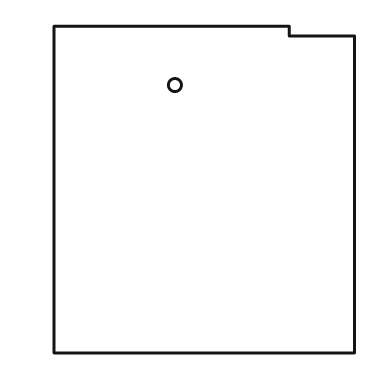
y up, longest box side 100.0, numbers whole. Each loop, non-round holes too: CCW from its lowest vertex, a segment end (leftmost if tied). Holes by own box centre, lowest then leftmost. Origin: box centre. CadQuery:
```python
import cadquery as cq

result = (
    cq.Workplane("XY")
    .moveTo(-46.0, -50.0)
    .lineTo(46.0, -50.0)
    .lineTo(46.0, 47.0)
    .lineTo(26.0, 47.0)
    .lineTo(26.0, 50.0)
    .lineTo(-46.0, 50.0)
    .close()
    .moveTo(-9.0, 32.0)
    .circle(2.0)
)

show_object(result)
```